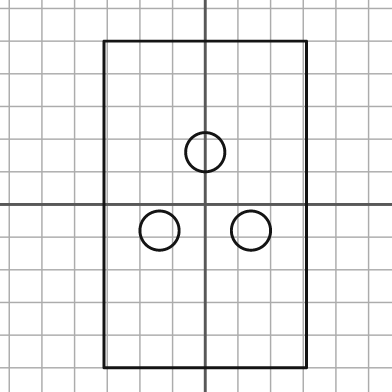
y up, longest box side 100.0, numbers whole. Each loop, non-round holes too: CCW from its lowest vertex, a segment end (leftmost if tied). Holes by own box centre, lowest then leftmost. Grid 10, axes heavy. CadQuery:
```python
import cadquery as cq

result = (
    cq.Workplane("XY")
    .moveTo(-31.0, -50.0)
    .lineTo(31.0, -50.0)
    .lineTo(31.0, 50.0)
    .lineTo(-31.0, 50.0)
    .close()
    .moveTo(-14.0, -8.0)
    .circle(6.0)
    .moveTo(14.0, -8.0)
    .circle(6.0)
    .moveTo(0.0, 16.0)
    .circle(6.0)
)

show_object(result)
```